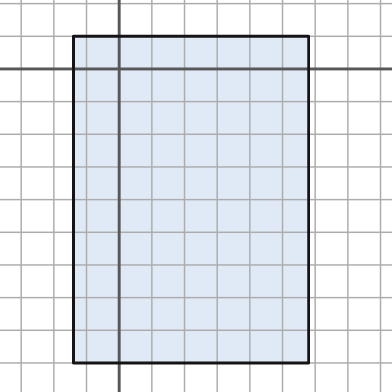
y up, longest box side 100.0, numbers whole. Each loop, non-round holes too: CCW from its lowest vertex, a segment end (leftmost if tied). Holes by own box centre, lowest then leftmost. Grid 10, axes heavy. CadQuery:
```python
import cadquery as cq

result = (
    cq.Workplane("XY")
    .moveTo(-14.0, -90.0)
    .lineTo(58.0, -90.0)
    .lineTo(58.0, 10.0)
    .lineTo(-14.0, 10.0)
    .close()
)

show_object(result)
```